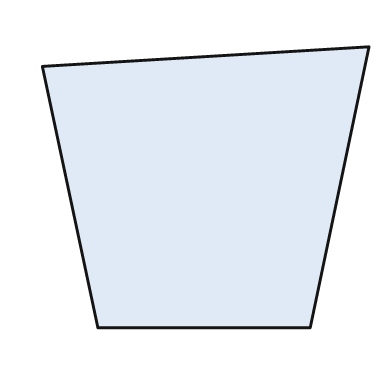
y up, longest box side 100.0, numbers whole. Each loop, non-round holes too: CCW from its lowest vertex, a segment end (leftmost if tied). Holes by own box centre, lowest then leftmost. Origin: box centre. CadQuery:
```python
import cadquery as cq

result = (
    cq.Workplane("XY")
    .moveTo(-33.0, -43.0)
    .lineTo(32.0, -43.0)
    .lineTo(50.0, 43.0)
    .lineTo(-50.0, 37.0)
    .close()
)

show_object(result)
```